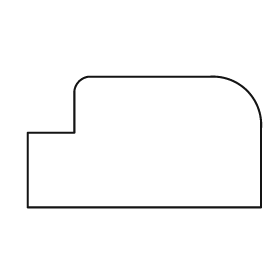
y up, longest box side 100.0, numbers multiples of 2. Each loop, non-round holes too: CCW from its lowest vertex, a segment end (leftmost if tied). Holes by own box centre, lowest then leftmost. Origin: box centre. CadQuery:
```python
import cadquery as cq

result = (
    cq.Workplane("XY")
    .moveTo(-50.0, -28.0)
    .lineTo(50.0, -28.0)
    .lineTo(50.0, 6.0)
    .threePointArc((44.0, 22.0), (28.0, 28.0))
    .lineTo(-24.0, 28.0)
    .threePointArc((-28.0, 26.0), (-30.0, 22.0))
    .lineTo(-30.0, 4.0)
    .lineTo(-50.0, 4.0)
    .close()
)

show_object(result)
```